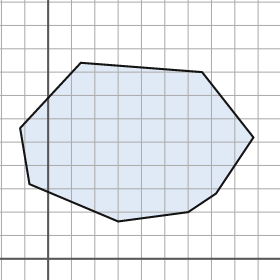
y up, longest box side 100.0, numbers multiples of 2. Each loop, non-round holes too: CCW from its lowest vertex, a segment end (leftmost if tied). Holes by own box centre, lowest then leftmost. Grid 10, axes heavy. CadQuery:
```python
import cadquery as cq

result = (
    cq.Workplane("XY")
    .moveTo(30.0, 16.0)
    .lineTo(60.0, 20.0)
    .lineTo(72.0, 28.0)
    .lineTo(88.0, 52.0)
    .lineTo(66.0, 80.0)
    .lineTo(14.0, 84.0)
    .lineTo(-12.0, 56.0)
    .lineTo(-8.0, 32.0)
    .close()
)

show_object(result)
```